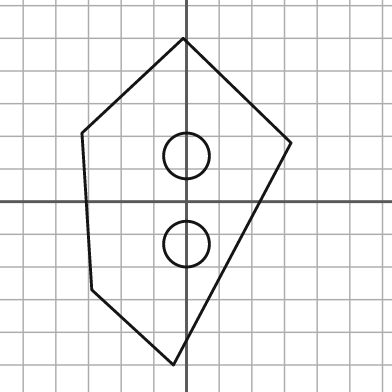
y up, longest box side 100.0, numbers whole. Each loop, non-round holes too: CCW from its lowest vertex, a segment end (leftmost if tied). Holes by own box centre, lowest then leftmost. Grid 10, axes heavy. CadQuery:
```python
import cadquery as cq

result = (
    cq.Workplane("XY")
    .moveTo(-4.0, -50.0)
    .lineTo(32.0, 18.0)
    .lineTo(-1.0, 50.0)
    .lineTo(-32.0, 21.0)
    .lineTo(-29.0, -27.0)
    .close()
    .moveTo(0.0, -13.0)
    .circle(7.0)
    .moveTo(0.0, 14.0)
    .circle(7.0)
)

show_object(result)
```